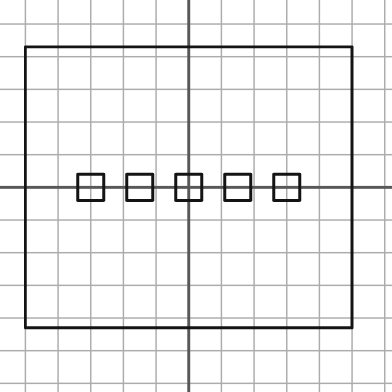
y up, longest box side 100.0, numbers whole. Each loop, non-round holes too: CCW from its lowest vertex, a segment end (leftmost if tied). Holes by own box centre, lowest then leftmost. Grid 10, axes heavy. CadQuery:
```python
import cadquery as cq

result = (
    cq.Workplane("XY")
    .moveTo(-50.0, -43.0)
    .lineTo(50.0, -43.0)
    .lineTo(50.0, 43.0)
    .lineTo(-50.0, 43.0)
    .close()
    .moveTo(-34.0, -4.0)
    .lineTo(-26.0, -4.0)
    .lineTo(-26.0, 4.0)
    .lineTo(-34.0, 4.0)
    .close()
    .moveTo(-19.0, -4.0)
    .lineTo(-11.0, -4.0)
    .lineTo(-11.0, 4.0)
    .lineTo(-19.0, 4.0)
    .close()
    .moveTo(-4.0, -4.0)
    .lineTo(4.0, -4.0)
    .lineTo(4.0, 4.0)
    .lineTo(-4.0, 4.0)
    .close()
    .moveTo(11.0, -4.0)
    .lineTo(19.0, -4.0)
    .lineTo(19.0, 4.0)
    .lineTo(11.0, 4.0)
    .close()
    .moveTo(26.0, -4.0)
    .lineTo(34.0, -4.0)
    .lineTo(34.0, 4.0)
    .lineTo(26.0, 4.0)
    .close()
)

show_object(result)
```